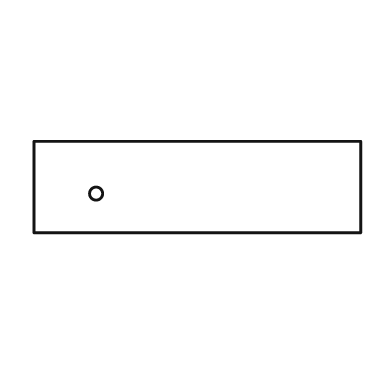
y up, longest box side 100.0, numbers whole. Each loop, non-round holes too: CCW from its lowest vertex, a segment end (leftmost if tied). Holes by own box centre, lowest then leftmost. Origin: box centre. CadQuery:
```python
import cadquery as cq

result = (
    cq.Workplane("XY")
    .moveTo(-50.0, -14.0)
    .lineTo(50.0, -14.0)
    .lineTo(50.0, 14.0)
    .lineTo(-50.0, 14.0)
    .close()
    .moveTo(-31.0, -2.0)
    .circle(2.0)
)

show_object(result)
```